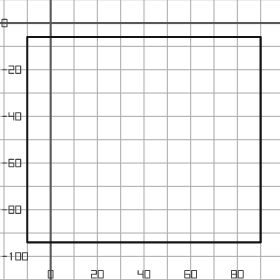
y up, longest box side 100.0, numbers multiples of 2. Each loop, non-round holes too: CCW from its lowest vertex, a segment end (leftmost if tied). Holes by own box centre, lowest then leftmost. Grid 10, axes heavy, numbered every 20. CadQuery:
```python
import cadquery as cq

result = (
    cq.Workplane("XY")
    .moveTo(-10.0, -94.0)
    .lineTo(90.0, -94.0)
    .lineTo(90.0, -6.0)
    .lineTo(-10.0, -6.0)
    .close()
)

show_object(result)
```